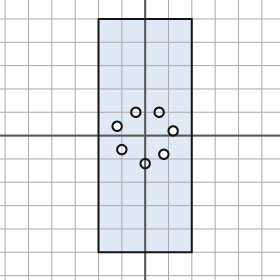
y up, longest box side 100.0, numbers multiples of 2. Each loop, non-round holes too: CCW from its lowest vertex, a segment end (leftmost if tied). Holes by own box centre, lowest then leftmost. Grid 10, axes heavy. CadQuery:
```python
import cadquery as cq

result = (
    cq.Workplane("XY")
    .moveTo(-20.0, -50.0)
    .lineTo(20.0, -50.0)
    .lineTo(20.0, 50.0)
    .lineTo(-20.0, 50.0)
    .close()
    .moveTo(0.0, -12.0)
    .circle(2.0)
    .moveTo(8.0, -8.0)
    .circle(2.0)
    .moveTo(-10.0, -6.0)
    .circle(2.0)
    .moveTo(12.0, 2.0)
    .circle(2.0)
    .moveTo(-12.0, 4.0)
    .circle(2.0)
    .moveTo(-4.0, 10.0)
    .circle(2.0)
    .moveTo(6.0, 10.0)
    .circle(2.0)
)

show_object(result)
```